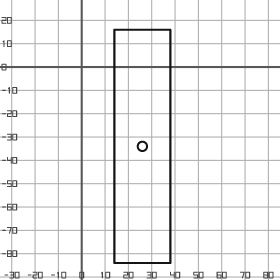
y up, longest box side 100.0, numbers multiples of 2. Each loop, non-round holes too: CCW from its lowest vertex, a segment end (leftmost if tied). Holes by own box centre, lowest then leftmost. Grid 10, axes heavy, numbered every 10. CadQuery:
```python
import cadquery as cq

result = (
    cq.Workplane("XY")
    .moveTo(14.0, -84.0)
    .lineTo(38.0, -84.0)
    .lineTo(38.0, 16.0)
    .lineTo(14.0, 16.0)
    .close()
    .moveTo(26.0, -34.0)
    .circle(2.0)
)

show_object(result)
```